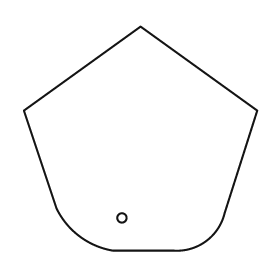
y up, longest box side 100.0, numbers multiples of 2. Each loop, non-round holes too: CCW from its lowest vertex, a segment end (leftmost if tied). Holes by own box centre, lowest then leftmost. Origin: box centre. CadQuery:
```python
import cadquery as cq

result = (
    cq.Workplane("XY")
    .moveTo(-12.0, -48.0)
    .lineTo(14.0, -48.0)
    .threePointArc((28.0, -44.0), (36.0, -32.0))
    .lineTo(50.0, 12.0)
    .lineTo(0.0, 48.0)
    .lineTo(-50.0, 12.0)
    .lineTo(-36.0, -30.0)
    .threePointArc((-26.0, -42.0), (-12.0, -48.0))
    .close()
    .moveTo(-8.0, -34.0)
    .circle(2.0)
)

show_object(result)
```